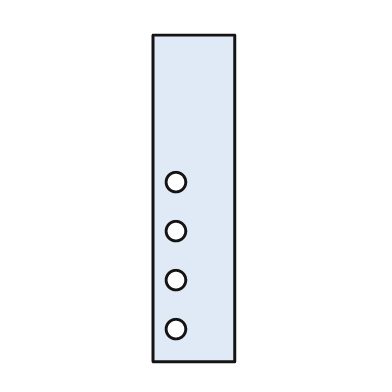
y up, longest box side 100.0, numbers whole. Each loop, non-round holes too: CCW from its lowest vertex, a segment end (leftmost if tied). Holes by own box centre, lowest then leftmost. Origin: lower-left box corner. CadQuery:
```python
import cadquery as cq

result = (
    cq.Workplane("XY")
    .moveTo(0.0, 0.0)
    .lineTo(25.0, 0.0)
    .lineTo(25.0, 100.0)
    .lineTo(0.0, 100.0)
    .close()
    .moveTo(7.0, 10.0)
    .circle(3.0)
    .moveTo(7.0, 25.0)
    .circle(3.0)
    .moveTo(7.0, 40.0)
    .circle(3.0)
    .moveTo(7.0, 55.0)
    .circle(3.0)
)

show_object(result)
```